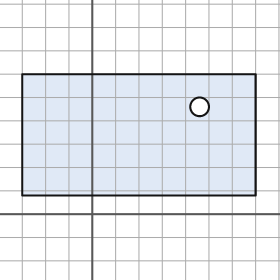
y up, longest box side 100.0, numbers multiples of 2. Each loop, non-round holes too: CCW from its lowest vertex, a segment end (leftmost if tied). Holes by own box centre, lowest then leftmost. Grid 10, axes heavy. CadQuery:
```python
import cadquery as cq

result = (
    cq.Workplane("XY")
    .moveTo(-30.0, 8.0)
    .lineTo(70.0, 8.0)
    .lineTo(70.0, 60.0)
    .lineTo(-30.0, 60.0)
    .close()
    .moveTo(46.0, 46.0)
    .circle(4.0)
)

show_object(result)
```